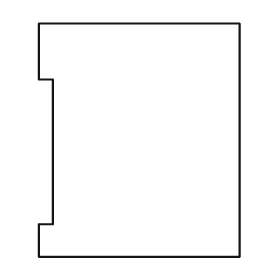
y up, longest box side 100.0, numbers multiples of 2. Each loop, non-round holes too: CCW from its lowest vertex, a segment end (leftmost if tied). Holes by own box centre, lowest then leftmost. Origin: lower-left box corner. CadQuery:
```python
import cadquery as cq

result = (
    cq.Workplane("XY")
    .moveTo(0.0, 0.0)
    .lineTo(86.0, 0.0)
    .lineTo(86.0, 100.0)
    .lineTo(0.0, 100.0)
    .lineTo(0.0, 76.0)
    .lineTo(6.0, 76.0)
    .lineTo(6.0, 14.0)
    .lineTo(0.0, 14.0)
    .close()
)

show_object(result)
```